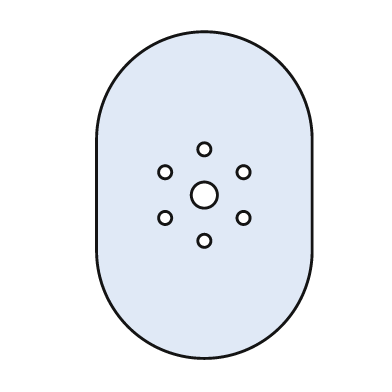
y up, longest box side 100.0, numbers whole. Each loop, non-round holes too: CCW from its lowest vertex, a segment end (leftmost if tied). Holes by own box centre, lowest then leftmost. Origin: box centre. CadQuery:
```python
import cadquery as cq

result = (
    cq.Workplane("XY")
    .moveTo(-33.0, -17.0)
    .threePointArc((0.0, -50.0), (33.0, -17.0))
    .lineTo(33.0, 17.0)
    .threePointArc((0.0, 50.0), (-33.0, 17.0))
    .close()
    .moveTo(0.0, -14.0)
    .circle(2.0)
    .moveTo(-12.0, -7.0)
    .circle(2.0)
    .moveTo(12.0, -7.0)
    .circle(2.0)
    .moveTo(0.0, 0.0)
    .circle(4.0)
    .moveTo(-12.0, 7.0)
    .circle(2.0)
    .moveTo(12.0, 7.0)
    .circle(2.0)
    .moveTo(0.0, 14.0)
    .circle(2.0)
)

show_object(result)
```